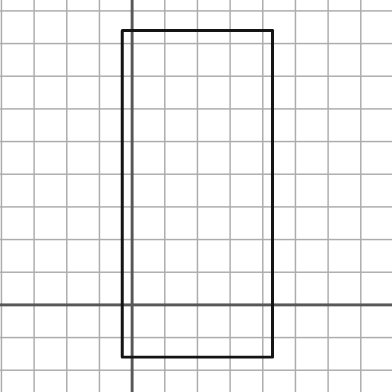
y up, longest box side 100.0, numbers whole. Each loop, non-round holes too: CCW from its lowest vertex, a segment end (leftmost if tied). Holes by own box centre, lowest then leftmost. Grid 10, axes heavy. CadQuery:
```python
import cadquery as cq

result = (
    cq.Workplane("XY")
    .moveTo(-3.0, -16.0)
    .lineTo(43.0, -16.0)
    .lineTo(43.0, 84.0)
    .lineTo(-3.0, 84.0)
    .close()
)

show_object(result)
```